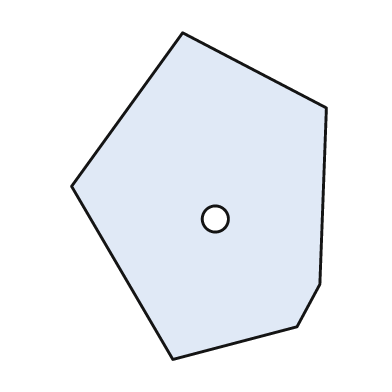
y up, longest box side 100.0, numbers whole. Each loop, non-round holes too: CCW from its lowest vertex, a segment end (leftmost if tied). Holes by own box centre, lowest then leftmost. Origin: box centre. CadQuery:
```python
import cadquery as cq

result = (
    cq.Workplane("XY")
    .moveTo(-8.0, -50.0)
    .lineTo(30.0, -40.0)
    .lineTo(37.0, -27.0)
    .lineTo(39.0, 27.0)
    .lineTo(-5.0, 50.0)
    .lineTo(-39.0, 3.0)
    .close()
    .moveTo(5.0, -7.0)
    .circle(4.0)
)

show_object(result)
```